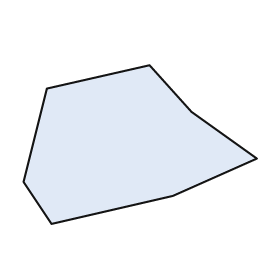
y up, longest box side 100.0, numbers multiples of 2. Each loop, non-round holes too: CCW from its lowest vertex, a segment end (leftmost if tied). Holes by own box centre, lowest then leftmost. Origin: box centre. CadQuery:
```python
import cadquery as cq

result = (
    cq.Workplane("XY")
    .moveTo(-38.0, -34.0)
    .lineTo(14.0, -22.0)
    .lineTo(50.0, -6.0)
    .lineTo(22.0, 14.0)
    .lineTo(4.0, 34.0)
    .lineTo(-40.0, 24.0)
    .lineTo(-50.0, -16.0)
    .close()
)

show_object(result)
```